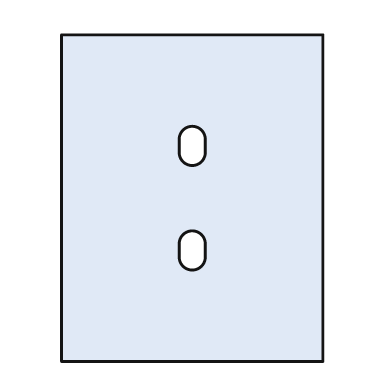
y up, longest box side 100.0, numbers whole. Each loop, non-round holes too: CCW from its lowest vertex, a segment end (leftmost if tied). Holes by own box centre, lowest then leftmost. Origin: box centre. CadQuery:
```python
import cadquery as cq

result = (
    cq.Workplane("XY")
    .moveTo(-40.0, -50.0)
    .lineTo(40.0, -50.0)
    .lineTo(40.0, 50.0)
    .lineTo(-40.0, 50.0)
    .close()
    .moveTo(-4.0, -18.0)
    .threePointArc((0.0, -22.0), (4.0, -18.0))
    .lineTo(4.0, -14.0)
    .threePointArc((0.0, -10.0), (-4.0, -14.0))
    .close()
    .moveTo(-4.0, 14.0)
    .threePointArc((0.0, 10.0), (4.0, 14.0))
    .lineTo(4.0, 18.0)
    .threePointArc((0.0, 22.0), (-4.0, 18.0))
    .close()
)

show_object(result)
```